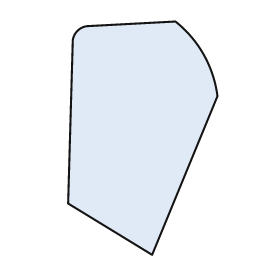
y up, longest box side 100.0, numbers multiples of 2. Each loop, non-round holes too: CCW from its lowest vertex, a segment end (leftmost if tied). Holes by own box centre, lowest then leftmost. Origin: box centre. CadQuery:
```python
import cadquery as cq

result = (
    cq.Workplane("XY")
    .moveTo(4.0, -50.0)
    .lineTo(32.0, 18.0)
    .threePointArc((26.0, 36.0), (14.0, 50.0))
    .lineTo(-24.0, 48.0)
    .threePointArc((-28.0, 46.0), (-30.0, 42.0))
    .lineTo(-32.0, -28.0)
    .close()
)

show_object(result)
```